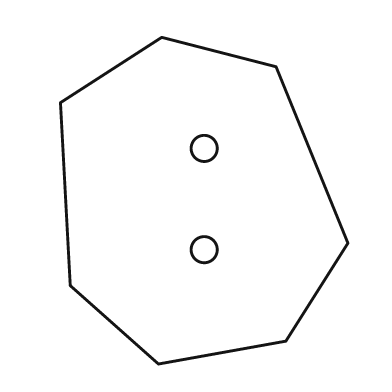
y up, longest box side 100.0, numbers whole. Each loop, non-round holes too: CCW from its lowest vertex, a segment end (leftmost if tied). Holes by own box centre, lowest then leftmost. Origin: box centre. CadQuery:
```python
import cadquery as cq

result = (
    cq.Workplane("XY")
    .moveTo(-14.0, -50.0)
    .lineTo(25.0, -43.0)
    .lineTo(44.0, -13.0)
    .lineTo(22.0, 41.0)
    .lineTo(-13.0, 50.0)
    .lineTo(-44.0, 30.0)
    .lineTo(-41.0, -26.0)
    .close()
    .moveTo(0.0, -15.0)
    .circle(4.0)
    .moveTo(0.0, 16.0)
    .circle(4.0)
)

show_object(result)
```